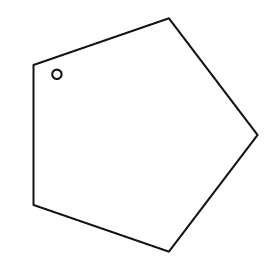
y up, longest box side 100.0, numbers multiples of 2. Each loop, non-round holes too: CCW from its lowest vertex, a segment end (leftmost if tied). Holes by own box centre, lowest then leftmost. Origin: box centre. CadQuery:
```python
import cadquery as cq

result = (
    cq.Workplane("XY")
    .moveTo(10.0, -50.0)
    .lineTo(48.0, 0.0)
    .lineTo(10.0, 50.0)
    .lineTo(-48.0, 30.0)
    .lineTo(-48.0, -30.0)
    .close()
    .moveTo(-38.0, 26.0)
    .circle(2.0)
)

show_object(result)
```